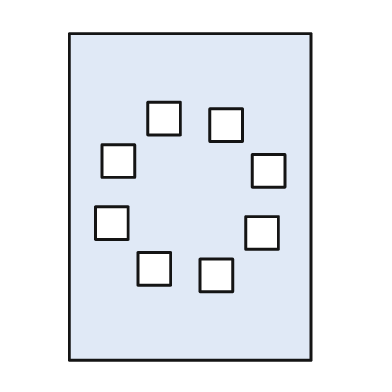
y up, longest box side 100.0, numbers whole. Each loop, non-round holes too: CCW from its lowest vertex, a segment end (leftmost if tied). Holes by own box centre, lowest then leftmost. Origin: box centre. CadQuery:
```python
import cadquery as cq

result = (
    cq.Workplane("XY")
    .moveTo(-37.0, -50.0)
    .lineTo(37.0, -50.0)
    .lineTo(37.0, 50.0)
    .lineTo(-37.0, 50.0)
    .close()
    .moveTo(3.0, -29.0)
    .lineTo(13.0, -29.0)
    .lineTo(13.0, -19.0)
    .lineTo(3.0, -19.0)
    .close()
    .moveTo(-16.0, -27.0)
    .lineTo(-6.0, -27.0)
    .lineTo(-6.0, -17.0)
    .lineTo(-16.0, -17.0)
    .close()
    .moveTo(17.0, -16.0)
    .lineTo(27.0, -16.0)
    .lineTo(27.0, -6.0)
    .lineTo(17.0, -6.0)
    .close()
    .moveTo(-29.0, -13.0)
    .lineTo(-19.0, -13.0)
    .lineTo(-19.0, -3.0)
    .lineTo(-29.0, -3.0)
    .close()
    .moveTo(19.0, 3.0)
    .lineTo(29.0, 3.0)
    .lineTo(29.0, 13.0)
    .lineTo(19.0, 13.0)
    .close()
    .moveTo(-27.0, 6.0)
    .lineTo(-17.0, 6.0)
    .lineTo(-17.0, 16.0)
    .lineTo(-27.0, 16.0)
    .close()
    .moveTo(6.0, 17.0)
    .lineTo(16.0, 17.0)
    .lineTo(16.0, 27.0)
    .lineTo(6.0, 27.0)
    .close()
    .moveTo(-13.0, 19.0)
    .lineTo(-3.0, 19.0)
    .lineTo(-3.0, 29.0)
    .lineTo(-13.0, 29.0)
    .close()
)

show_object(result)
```